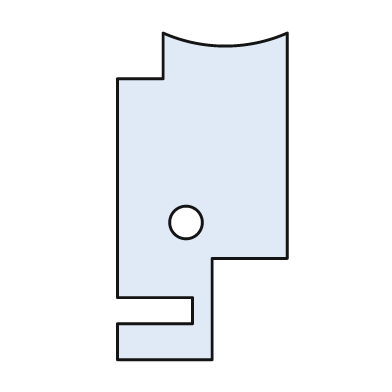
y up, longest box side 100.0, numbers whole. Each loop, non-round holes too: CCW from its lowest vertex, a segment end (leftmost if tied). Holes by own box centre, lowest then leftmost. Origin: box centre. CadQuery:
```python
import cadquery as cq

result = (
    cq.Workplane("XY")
    .moveTo(-26.0, -50.0)
    .lineTo(3.0, -50.0)
    .lineTo(3.0, -19.0)
    .lineTo(26.0, -19.0)
    .lineTo(26.0, 50.0)
    .threePointArc((7.0, 46.0), (-12.0, 50.0))
    .lineTo(-12.0, 36.0)
    .lineTo(-26.0, 36.0)
    .lineTo(-26.0, -31.0)
    .lineTo(-3.0, -31.0)
    .lineTo(-3.0, -39.0)
    .lineTo(-26.0, -39.0)
    .close()
    .moveTo(-5.0, -8.0)
    .circle(5.0)
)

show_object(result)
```